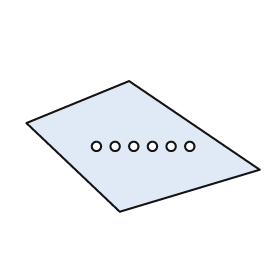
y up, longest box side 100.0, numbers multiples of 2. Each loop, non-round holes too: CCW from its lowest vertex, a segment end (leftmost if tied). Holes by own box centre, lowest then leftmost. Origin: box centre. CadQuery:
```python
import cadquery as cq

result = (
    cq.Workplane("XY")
    .moveTo(-10.0, -28.0)
    .lineTo(50.0, -10.0)
    .lineTo(-6.0, 28.0)
    .lineTo(-50.0, 10.0)
    .close()
    .moveTo(-20.0, 0.0)
    .circle(2.0)
    .moveTo(-12.0, 0.0)
    .circle(2.0)
    .moveTo(-4.0, 0.0)
    .circle(2.0)
    .moveTo(4.0, 0.0)
    .circle(2.0)
    .moveTo(12.0, 0.0)
    .circle(2.0)
    .moveTo(20.0, 0.0)
    .circle(2.0)
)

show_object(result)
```